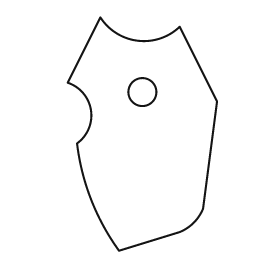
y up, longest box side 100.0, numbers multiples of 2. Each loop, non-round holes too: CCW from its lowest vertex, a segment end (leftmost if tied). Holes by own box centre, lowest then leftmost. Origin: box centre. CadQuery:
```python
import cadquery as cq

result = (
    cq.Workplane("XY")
    .moveTo(-10.0, -50.0)
    .lineTo(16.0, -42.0)
    .threePointArc((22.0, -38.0), (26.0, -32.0))
    .lineTo(32.0, 14.0)
    .lineTo(16.0, 46.0)
    .threePointArc((-2.0, 40.0), (-18.0, 50.0))
    .lineTo(-32.0, 22.0)
    .threePointArc((-22.0, 10.0), (-28.0, -4.0))
    .threePointArc((-22.0, -28.0), (-10.0, -50.0))
    .close()
    .moveTo(0.0, 18.0)
    .circle(6.0)
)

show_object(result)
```